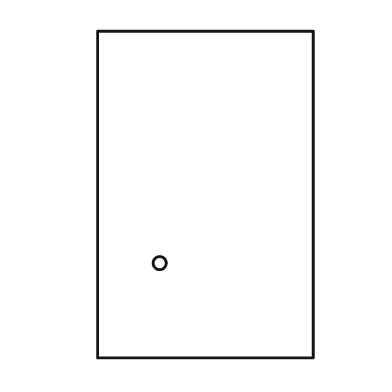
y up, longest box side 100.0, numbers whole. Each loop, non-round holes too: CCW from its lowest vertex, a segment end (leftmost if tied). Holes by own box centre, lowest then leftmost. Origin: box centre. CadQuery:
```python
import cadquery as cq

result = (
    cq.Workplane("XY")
    .moveTo(-33.0, -50.0)
    .lineTo(33.0, -50.0)
    .lineTo(33.0, 50.0)
    .lineTo(-33.0, 50.0)
    .close()
    .moveTo(-14.0, -21.0)
    .circle(2.0)
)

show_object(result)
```